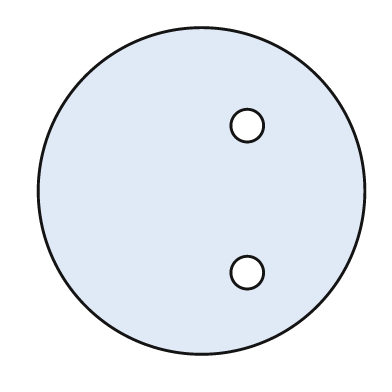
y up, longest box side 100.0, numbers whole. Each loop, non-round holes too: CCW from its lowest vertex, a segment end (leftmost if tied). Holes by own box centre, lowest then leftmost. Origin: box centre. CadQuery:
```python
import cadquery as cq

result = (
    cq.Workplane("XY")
    .moveTo(0.0, 0.0)
    .circle(50.0)
    .moveTo(14.0, -25.0)
    .circle(5.0)
    .moveTo(14.0, 20.0)
    .circle(5.0)
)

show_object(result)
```